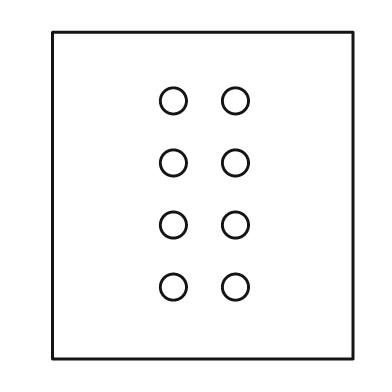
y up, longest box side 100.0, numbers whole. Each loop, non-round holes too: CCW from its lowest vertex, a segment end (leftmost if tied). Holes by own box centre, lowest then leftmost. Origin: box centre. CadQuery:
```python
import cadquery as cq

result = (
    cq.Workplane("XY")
    .moveTo(-46.0, -50.0)
    .lineTo(46.0, -50.0)
    .lineTo(46.0, 50.0)
    .lineTo(-46.0, 50.0)
    .close()
    .moveTo(-9.0, -28.0)
    .circle(4.0)
    .moveTo(10.0, -28.0)
    .circle(4.0)
    .moveTo(-9.0, -9.0)
    .circle(4.0)
    .moveTo(10.0, -9.0)
    .circle(4.0)
    .moveTo(-9.0, 10.0)
    .circle(4.0)
    .moveTo(10.0, 10.0)
    .circle(4.0)
    .moveTo(-9.0, 29.0)
    .circle(4.0)
    .moveTo(10.0, 29.0)
    .circle(4.0)
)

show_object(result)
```